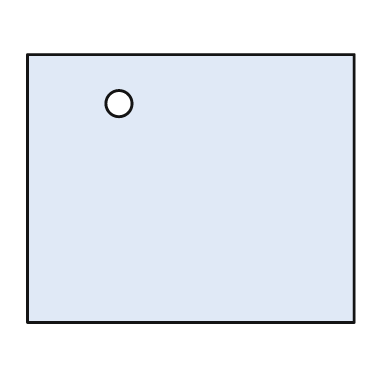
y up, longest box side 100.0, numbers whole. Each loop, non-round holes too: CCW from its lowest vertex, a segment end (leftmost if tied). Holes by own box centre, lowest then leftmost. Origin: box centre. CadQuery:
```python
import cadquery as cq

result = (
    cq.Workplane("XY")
    .moveTo(-50.0, -41.0)
    .lineTo(50.0, -41.0)
    .lineTo(50.0, 41.0)
    .lineTo(-50.0, 41.0)
    .close()
    .moveTo(-22.0, 26.0)
    .circle(4.0)
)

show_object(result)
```